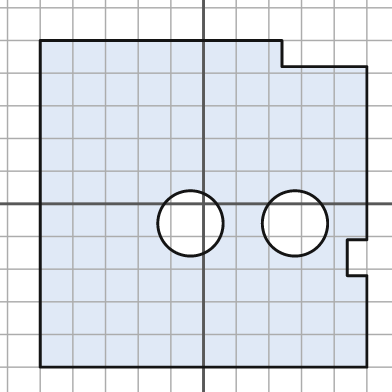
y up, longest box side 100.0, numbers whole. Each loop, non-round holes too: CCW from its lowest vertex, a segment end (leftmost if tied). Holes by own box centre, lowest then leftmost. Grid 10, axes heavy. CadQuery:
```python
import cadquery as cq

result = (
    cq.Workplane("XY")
    .moveTo(-50.0, -50.0)
    .lineTo(50.0, -50.0)
    .lineTo(50.0, -22.0)
    .lineTo(44.0, -22.0)
    .lineTo(44.0, -11.0)
    .lineTo(50.0, -11.0)
    .lineTo(50.0, 42.0)
    .lineTo(24.0, 42.0)
    .lineTo(24.0, 50.0)
    .lineTo(-50.0, 50.0)
    .close()
    .moveTo(-4.0, -6.0)
    .circle(10.0)
    .moveTo(28.0, -6.0)
    .circle(10.0)
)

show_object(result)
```